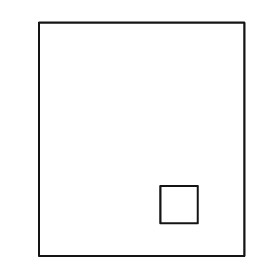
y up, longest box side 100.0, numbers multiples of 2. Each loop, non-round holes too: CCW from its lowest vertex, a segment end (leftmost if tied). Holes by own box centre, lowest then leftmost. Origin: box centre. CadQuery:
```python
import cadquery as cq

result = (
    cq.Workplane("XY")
    .moveTo(-44.0, -50.0)
    .lineTo(44.0, -50.0)
    .lineTo(44.0, 50.0)
    .lineTo(-44.0, 50.0)
    .close()
    .moveTo(8.0, -36.0)
    .lineTo(24.0, -36.0)
    .lineTo(24.0, -20.0)
    .lineTo(8.0, -20.0)
    .close()
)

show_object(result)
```